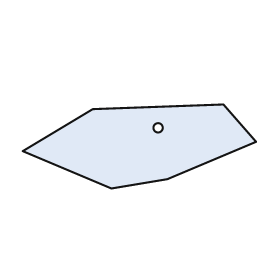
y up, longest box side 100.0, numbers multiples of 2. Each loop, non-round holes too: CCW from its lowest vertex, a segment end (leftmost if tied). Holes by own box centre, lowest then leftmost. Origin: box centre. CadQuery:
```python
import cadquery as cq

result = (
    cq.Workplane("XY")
    .moveTo(-12.0, -18.0)
    .lineTo(12.0, -14.0)
    .lineTo(50.0, 2.0)
    .lineTo(36.0, 18.0)
    .lineTo(-20.0, 16.0)
    .lineTo(-50.0, -2.0)
    .close()
    .moveTo(8.0, 8.0)
    .circle(2.0)
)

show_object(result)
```